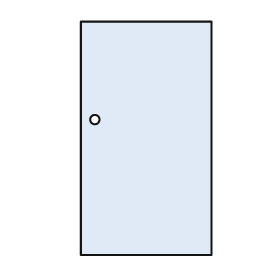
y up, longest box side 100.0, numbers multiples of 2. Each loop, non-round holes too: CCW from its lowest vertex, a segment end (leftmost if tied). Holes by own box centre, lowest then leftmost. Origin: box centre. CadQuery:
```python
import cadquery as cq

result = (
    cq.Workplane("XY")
    .moveTo(-28.0, -50.0)
    .lineTo(28.0, -50.0)
    .lineTo(28.0, 50.0)
    .lineTo(-28.0, 50.0)
    .close()
    .moveTo(-22.0, 8.0)
    .circle(2.0)
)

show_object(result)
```